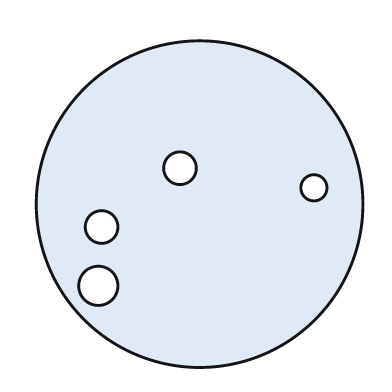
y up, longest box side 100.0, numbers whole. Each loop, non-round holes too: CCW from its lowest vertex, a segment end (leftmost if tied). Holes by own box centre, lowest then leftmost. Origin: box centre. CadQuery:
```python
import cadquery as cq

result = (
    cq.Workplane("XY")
    .moveTo(0.0, 0.0)
    .circle(50.0)
    .moveTo(-31.0, -25.0)
    .circle(6.0)
    .moveTo(-30.0, -7.0)
    .circle(5.0)
    .moveTo(35.0, 5.0)
    .circle(4.0)
    .moveTo(-6.0, 11.0)
    .circle(5.0)
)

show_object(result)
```